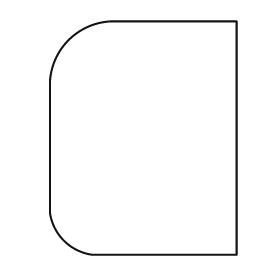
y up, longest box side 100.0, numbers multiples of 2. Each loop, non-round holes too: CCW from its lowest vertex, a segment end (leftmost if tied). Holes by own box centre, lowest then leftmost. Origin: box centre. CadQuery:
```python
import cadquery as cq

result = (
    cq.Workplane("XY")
    .moveTo(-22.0, -50.0)
    .lineTo(40.0, -50.0)
    .lineTo(40.0, 50.0)
    .lineTo(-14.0, 50.0)
    .threePointArc((-32.0, 42.0), (-40.0, 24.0))
    .lineTo(-40.0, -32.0)
    .threePointArc((-34.0, -44.0), (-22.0, -50.0))
    .close()
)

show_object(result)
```